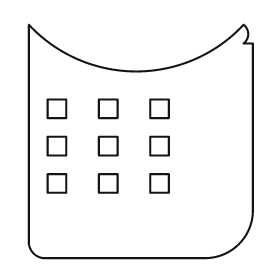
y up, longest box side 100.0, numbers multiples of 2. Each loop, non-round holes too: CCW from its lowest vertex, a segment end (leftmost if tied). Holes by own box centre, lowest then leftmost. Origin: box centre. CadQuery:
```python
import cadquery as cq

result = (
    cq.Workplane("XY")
    .moveTo(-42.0, -50.0)
    .lineTo(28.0, -50.0)
    .threePointArc((42.0, -44.0), (48.0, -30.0))
    .lineTo(48.0, 42.0)
    .lineTo(44.0, 42.0)
    .threePointArc((46.0, 46.0), (44.0, 50.0))
    .threePointArc((-2.0, 30.0), (-48.0, 50.0))
    .lineTo(-48.0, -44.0)
    .threePointArc((-46.0, -48.0), (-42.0, -50.0))
    .close()
    .moveTo(-40.0, -22.0)
    .lineTo(-32.0, -22.0)
    .lineTo(-32.0, -14.0)
    .lineTo(-40.0, -14.0)
    .close()
    .moveTo(-18.0, -22.0)
    .lineTo(-10.0, -22.0)
    .lineTo(-10.0, -14.0)
    .lineTo(-18.0, -14.0)
    .close()
    .moveTo(4.0, -22.0)
    .lineTo(12.0, -22.0)
    .lineTo(12.0, -14.0)
    .lineTo(4.0, -14.0)
    .close()
    .moveTo(-40.0, -6.0)
    .lineTo(-32.0, -6.0)
    .lineTo(-32.0, 2.0)
    .lineTo(-40.0, 2.0)
    .close()
    .moveTo(-18.0, -6.0)
    .lineTo(-10.0, -6.0)
    .lineTo(-10.0, 2.0)
    .lineTo(-18.0, 2.0)
    .close()
    .moveTo(4.0, -6.0)
    .lineTo(12.0, -6.0)
    .lineTo(12.0, 2.0)
    .lineTo(4.0, 2.0)
    .close()
    .moveTo(-40.0, 10.0)
    .lineTo(-32.0, 10.0)
    .lineTo(-32.0, 18.0)
    .lineTo(-40.0, 18.0)
    .close()
    .moveTo(-18.0, 10.0)
    .lineTo(-10.0, 10.0)
    .lineTo(-10.0, 18.0)
    .lineTo(-18.0, 18.0)
    .close()
    .moveTo(4.0, 10.0)
    .lineTo(12.0, 10.0)
    .lineTo(12.0, 18.0)
    .lineTo(4.0, 18.0)
    .close()
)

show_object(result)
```